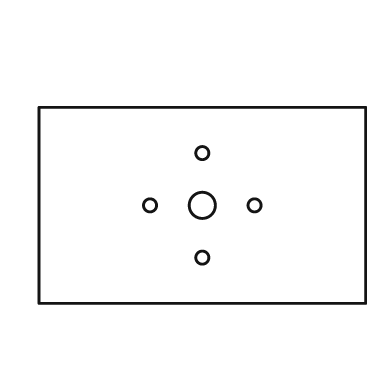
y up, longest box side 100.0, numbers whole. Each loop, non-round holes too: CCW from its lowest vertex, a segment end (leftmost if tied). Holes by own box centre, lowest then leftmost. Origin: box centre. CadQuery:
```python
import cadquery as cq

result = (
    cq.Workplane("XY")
    .moveTo(-50.0, -30.0)
    .lineTo(50.0, -30.0)
    .lineTo(50.0, 30.0)
    .lineTo(-50.0, 30.0)
    .close()
    .moveTo(0.0, -16.0)
    .circle(2.0)
    .moveTo(-16.0, 0.0)
    .circle(2.0)
    .moveTo(0.0, 0.0)
    .circle(4.0)
    .moveTo(16.0, 0.0)
    .circle(2.0)
    .moveTo(0.0, 16.0)
    .circle(2.0)
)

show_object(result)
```